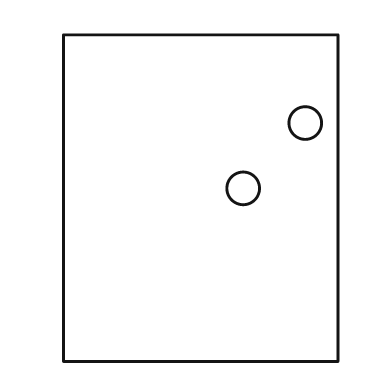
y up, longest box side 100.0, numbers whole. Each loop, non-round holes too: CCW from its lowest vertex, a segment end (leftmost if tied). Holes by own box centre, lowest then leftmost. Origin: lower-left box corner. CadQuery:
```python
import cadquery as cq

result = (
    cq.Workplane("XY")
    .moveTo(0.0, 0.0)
    .lineTo(84.0, 0.0)
    .lineTo(84.0, 100.0)
    .lineTo(0.0, 100.0)
    .close()
    .moveTo(55.0, 53.0)
    .circle(5.0)
    .moveTo(74.0, 73.0)
    .circle(5.0)
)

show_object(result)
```